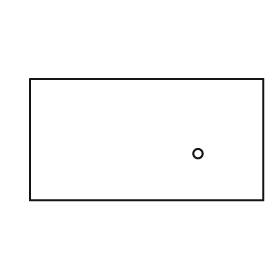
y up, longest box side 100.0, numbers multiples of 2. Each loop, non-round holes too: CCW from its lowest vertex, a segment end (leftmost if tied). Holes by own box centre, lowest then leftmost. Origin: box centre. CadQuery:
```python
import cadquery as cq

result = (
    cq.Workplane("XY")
    .moveTo(-50.0, -26.0)
    .lineTo(50.0, -26.0)
    .lineTo(50.0, 26.0)
    .lineTo(-50.0, 26.0)
    .close()
    .moveTo(22.0, -6.0)
    .circle(2.0)
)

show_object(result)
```